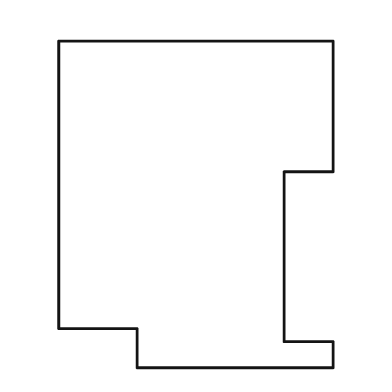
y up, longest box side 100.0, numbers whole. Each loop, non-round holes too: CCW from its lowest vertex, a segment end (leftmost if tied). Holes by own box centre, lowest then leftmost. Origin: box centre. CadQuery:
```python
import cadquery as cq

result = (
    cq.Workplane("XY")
    .moveTo(-18.0, -50.0)
    .lineTo(42.0, -50.0)
    .lineTo(42.0, -42.0)
    .lineTo(27.0, -42.0)
    .lineTo(27.0, 10.0)
    .lineTo(42.0, 10.0)
    .lineTo(42.0, 50.0)
    .lineTo(-42.0, 50.0)
    .lineTo(-42.0, -38.0)
    .lineTo(-18.0, -38.0)
    .close()
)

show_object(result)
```